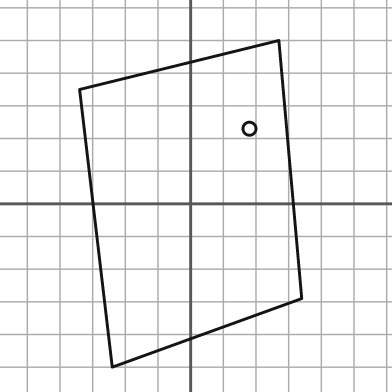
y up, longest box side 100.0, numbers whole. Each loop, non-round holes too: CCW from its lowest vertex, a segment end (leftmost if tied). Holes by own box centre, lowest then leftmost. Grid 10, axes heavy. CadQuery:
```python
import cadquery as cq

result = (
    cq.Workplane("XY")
    .moveTo(-24.0, -50.0)
    .lineTo(34.0, -29.0)
    .lineTo(27.0, 50.0)
    .lineTo(-34.0, 35.0)
    .close()
    .moveTo(18.0, 23.0)
    .circle(2.0)
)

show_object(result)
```